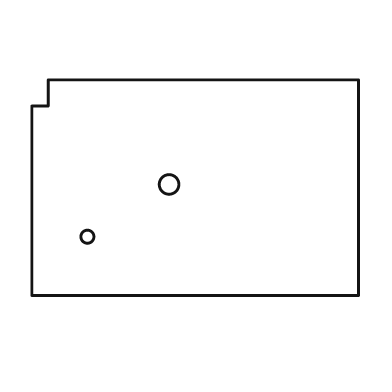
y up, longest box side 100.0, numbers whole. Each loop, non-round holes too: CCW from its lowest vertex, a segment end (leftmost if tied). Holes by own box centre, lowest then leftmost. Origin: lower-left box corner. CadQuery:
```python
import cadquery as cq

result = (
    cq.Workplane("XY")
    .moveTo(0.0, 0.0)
    .lineTo(100.0, 0.0)
    .lineTo(100.0, 66.0)
    .lineTo(5.0, 66.0)
    .lineTo(5.0, 58.0)
    .lineTo(0.0, 58.0)
    .close()
    .moveTo(17.0, 18.0)
    .circle(2.0)
    .moveTo(42.0, 34.0)
    .circle(3.0)
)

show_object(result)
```